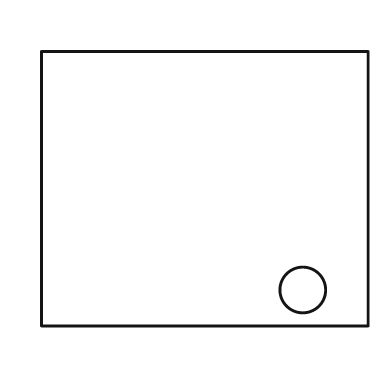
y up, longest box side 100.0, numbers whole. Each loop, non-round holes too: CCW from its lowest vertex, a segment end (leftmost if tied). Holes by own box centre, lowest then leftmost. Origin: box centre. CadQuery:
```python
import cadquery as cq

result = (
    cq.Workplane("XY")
    .moveTo(-50.0, -42.0)
    .lineTo(50.0, -42.0)
    .lineTo(50.0, 42.0)
    .lineTo(-50.0, 42.0)
    .close()
    .moveTo(30.0, -31.0)
    .circle(7.0)
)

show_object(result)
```